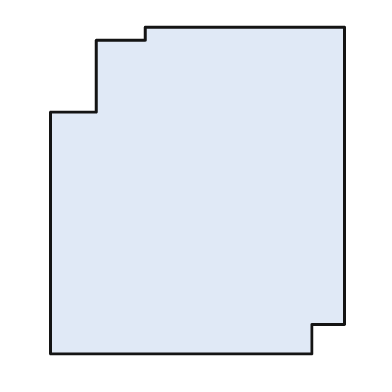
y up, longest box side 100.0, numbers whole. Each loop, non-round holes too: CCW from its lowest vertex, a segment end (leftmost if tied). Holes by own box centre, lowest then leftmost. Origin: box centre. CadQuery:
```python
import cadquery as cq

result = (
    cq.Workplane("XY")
    .moveTo(-45.0, -50.0)
    .lineTo(35.0, -50.0)
    .lineTo(35.0, -41.0)
    .lineTo(45.0, -41.0)
    .lineTo(45.0, 50.0)
    .lineTo(-16.0, 50.0)
    .lineTo(-16.0, 46.0)
    .lineTo(-31.0, 46.0)
    .lineTo(-31.0, 24.0)
    .lineTo(-45.0, 24.0)
    .close()
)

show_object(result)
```